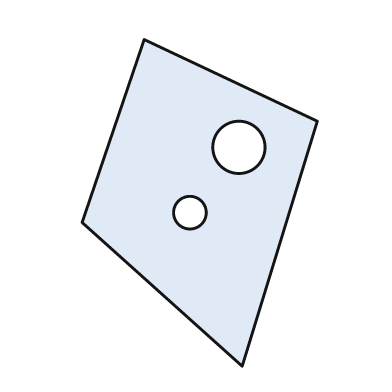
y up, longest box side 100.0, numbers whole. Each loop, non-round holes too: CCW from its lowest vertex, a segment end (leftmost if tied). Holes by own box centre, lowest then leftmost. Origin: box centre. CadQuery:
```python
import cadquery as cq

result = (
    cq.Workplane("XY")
    .moveTo(13.0, -50.0)
    .lineTo(36.0, 25.0)
    .lineTo(-17.0, 50.0)
    .lineTo(-36.0, -6.0)
    .close()
    .moveTo(-3.0, -3.0)
    .circle(5.0)
    .moveTo(12.0, 17.0)
    .circle(8.0)
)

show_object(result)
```